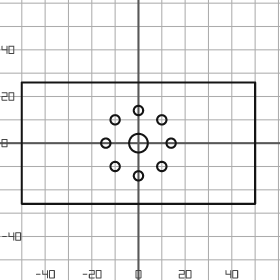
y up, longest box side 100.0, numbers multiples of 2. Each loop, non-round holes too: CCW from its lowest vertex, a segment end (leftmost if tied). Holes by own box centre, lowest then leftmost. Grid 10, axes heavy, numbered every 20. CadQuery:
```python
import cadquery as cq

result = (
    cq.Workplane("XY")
    .moveTo(-50.0, -26.0)
    .lineTo(50.0, -26.0)
    .lineTo(50.0, 26.0)
    .lineTo(-50.0, 26.0)
    .close()
    .moveTo(0.0, -14.0)
    .circle(2.0)
    .moveTo(-10.0, -10.0)
    .circle(2.0)
    .moveTo(10.0, -10.0)
    .circle(2.0)
    .moveTo(-14.0, 0.0)
    .circle(2.0)
    .moveTo(0.0, 0.0)
    .circle(4.0)
    .moveTo(14.0, 0.0)
    .circle(2.0)
    .moveTo(-10.0, 10.0)
    .circle(2.0)
    .moveTo(10.0, 10.0)
    .circle(2.0)
    .moveTo(0.0, 14.0)
    .circle(2.0)
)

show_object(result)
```